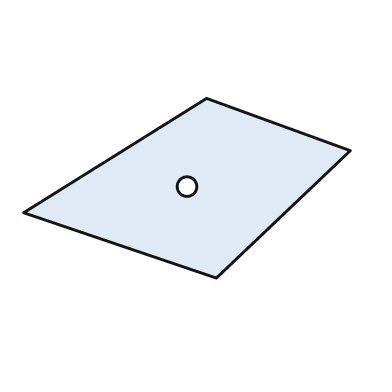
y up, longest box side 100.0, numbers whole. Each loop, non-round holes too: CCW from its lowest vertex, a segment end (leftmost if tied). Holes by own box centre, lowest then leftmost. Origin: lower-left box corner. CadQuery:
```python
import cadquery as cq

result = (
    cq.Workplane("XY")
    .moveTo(59.0, 0.0)
    .lineTo(100.0, 39.0)
    .lineTo(56.0, 55.0)
    .lineTo(0.0, 20.0)
    .close()
    .moveTo(50.0, 28.0)
    .circle(3.0)
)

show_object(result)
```